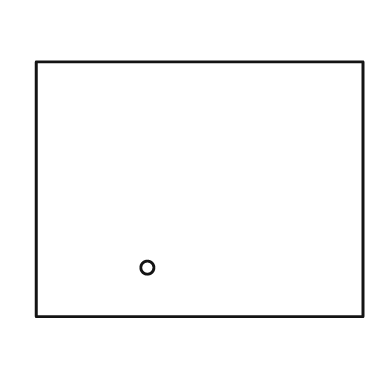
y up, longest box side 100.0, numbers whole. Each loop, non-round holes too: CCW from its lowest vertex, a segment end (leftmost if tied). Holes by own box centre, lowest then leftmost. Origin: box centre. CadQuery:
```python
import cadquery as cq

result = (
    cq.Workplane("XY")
    .moveTo(-50.0, -39.0)
    .lineTo(50.0, -39.0)
    .lineTo(50.0, 39.0)
    .lineTo(-50.0, 39.0)
    .close()
    .moveTo(-16.0, -24.0)
    .circle(2.0)
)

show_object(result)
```